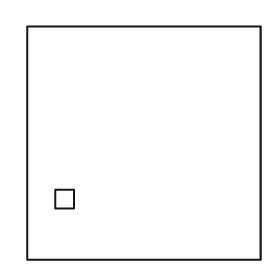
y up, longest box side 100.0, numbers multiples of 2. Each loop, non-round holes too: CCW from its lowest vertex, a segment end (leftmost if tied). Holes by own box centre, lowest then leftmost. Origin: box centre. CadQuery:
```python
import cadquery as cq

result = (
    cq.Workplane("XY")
    .moveTo(-50.0, -50.0)
    .lineTo(50.0, -50.0)
    .lineTo(50.0, 50.0)
    .lineTo(-50.0, 50.0)
    .close()
    .moveTo(-38.0, -28.0)
    .lineTo(-30.0, -28.0)
    .lineTo(-30.0, -20.0)
    .lineTo(-38.0, -20.0)
    .close()
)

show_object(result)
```